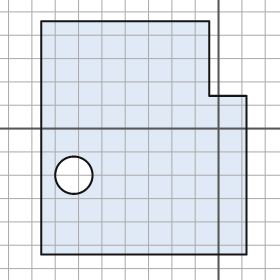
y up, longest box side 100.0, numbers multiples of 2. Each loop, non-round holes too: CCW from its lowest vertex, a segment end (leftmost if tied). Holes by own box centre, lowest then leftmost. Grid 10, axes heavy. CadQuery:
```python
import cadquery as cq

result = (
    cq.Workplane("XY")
    .moveTo(-76.0, -54.0)
    .lineTo(12.0, -54.0)
    .lineTo(12.0, 14.0)
    .lineTo(-4.0, 14.0)
    .lineTo(-4.0, 46.0)
    .lineTo(-76.0, 46.0)
    .close()
    .moveTo(-62.0, -20.0)
    .circle(8.0)
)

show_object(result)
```